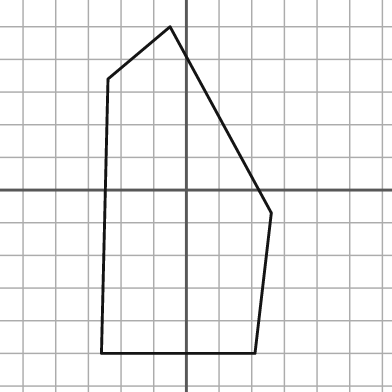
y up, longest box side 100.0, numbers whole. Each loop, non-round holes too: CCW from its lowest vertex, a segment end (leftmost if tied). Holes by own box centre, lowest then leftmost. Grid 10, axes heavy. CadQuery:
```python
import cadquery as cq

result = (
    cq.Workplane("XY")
    .moveTo(-26.0, -50.0)
    .lineTo(21.0, -50.0)
    .lineTo(26.0, -7.0)
    .lineTo(-5.0, 50.0)
    .lineTo(-24.0, 34.0)
    .close()
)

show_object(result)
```